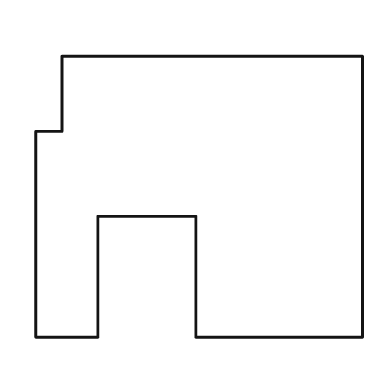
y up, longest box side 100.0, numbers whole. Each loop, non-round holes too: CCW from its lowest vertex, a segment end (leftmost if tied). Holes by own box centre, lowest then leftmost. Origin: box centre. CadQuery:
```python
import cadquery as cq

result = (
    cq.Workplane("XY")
    .moveTo(-50.0, -43.0)
    .lineTo(-31.0, -43.0)
    .lineTo(-31.0, -6.0)
    .lineTo(-1.0, -6.0)
    .lineTo(-1.0, -43.0)
    .lineTo(50.0, -43.0)
    .lineTo(50.0, 43.0)
    .lineTo(-42.0, 43.0)
    .lineTo(-42.0, 20.0)
    .lineTo(-50.0, 20.0)
    .close()
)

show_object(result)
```